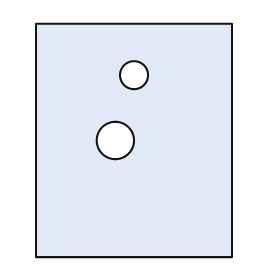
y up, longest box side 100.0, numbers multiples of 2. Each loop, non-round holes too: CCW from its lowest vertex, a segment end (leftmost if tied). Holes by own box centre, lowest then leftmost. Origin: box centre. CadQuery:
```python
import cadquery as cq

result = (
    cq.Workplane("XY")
    .moveTo(-42.0, -50.0)
    .lineTo(42.0, -50.0)
    .lineTo(42.0, 50.0)
    .lineTo(-42.0, 50.0)
    .close()
    .moveTo(-8.0, 0.0)
    .circle(8.0)
    .moveTo(0.0, 28.0)
    .circle(6.0)
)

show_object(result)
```